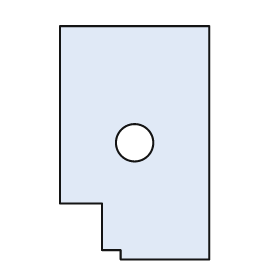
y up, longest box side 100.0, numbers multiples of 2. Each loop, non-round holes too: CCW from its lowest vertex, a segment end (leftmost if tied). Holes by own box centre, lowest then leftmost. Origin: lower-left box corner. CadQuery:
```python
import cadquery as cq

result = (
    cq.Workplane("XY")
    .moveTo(26.0, 0.0)
    .lineTo(64.0, 0.0)
    .lineTo(64.0, 100.0)
    .lineTo(0.0, 100.0)
    .lineTo(0.0, 24.0)
    .lineTo(18.0, 24.0)
    .lineTo(18.0, 4.0)
    .lineTo(26.0, 4.0)
    .close()
    .moveTo(32.0, 50.0)
    .circle(8.0)
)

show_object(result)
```